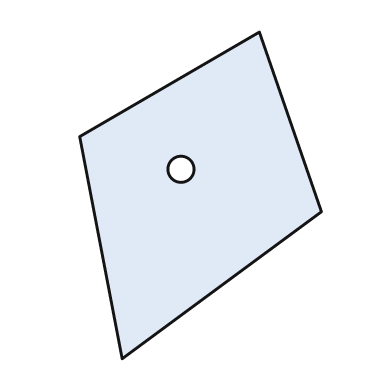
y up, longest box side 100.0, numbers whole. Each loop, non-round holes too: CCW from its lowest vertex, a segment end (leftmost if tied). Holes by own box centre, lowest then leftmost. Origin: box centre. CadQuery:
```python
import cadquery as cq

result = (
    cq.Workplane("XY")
    .moveTo(-24.0, -50.0)
    .lineTo(37.0, -5.0)
    .lineTo(18.0, 50.0)
    .lineTo(-37.0, 18.0)
    .close()
    .moveTo(-6.0, 8.0)
    .circle(4.0)
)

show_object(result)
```